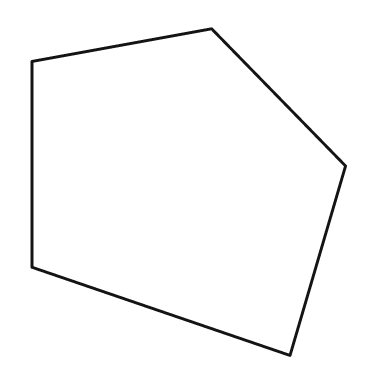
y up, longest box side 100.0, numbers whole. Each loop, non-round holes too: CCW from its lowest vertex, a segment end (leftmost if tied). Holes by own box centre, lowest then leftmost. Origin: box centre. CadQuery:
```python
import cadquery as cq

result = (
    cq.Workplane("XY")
    .moveTo(31.0, -50.0)
    .lineTo(48.0, 8.0)
    .lineTo(7.0, 50.0)
    .lineTo(-48.0, 40.0)
    .lineTo(-48.0, -23.0)
    .close()
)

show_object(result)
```